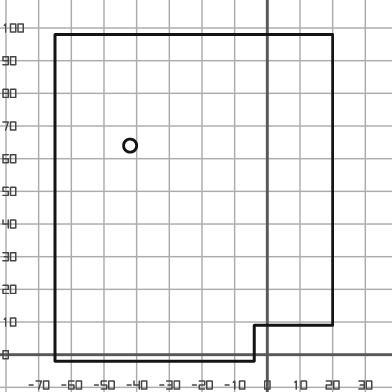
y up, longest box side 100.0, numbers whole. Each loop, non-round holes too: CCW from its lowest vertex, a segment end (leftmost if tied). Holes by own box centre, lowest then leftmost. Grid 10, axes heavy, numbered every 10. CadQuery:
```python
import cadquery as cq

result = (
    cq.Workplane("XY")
    .moveTo(-65.0, -2.0)
    .lineTo(-4.0, -2.0)
    .lineTo(-4.0, 9.0)
    .lineTo(20.0, 9.0)
    .lineTo(20.0, 98.0)
    .lineTo(-65.0, 98.0)
    .close()
    .moveTo(-42.0, 64.0)
    .circle(2.0)
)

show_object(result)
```